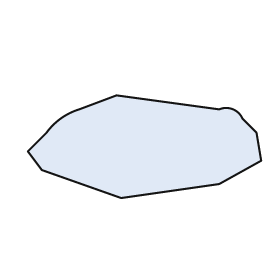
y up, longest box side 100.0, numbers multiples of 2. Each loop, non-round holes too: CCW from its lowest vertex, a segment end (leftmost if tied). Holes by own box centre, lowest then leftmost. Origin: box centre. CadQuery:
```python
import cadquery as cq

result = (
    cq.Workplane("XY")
    .moveTo(-10.0, -22.0)
    .lineTo(32.0, -16.0)
    .lineTo(50.0, -6.0)
    .lineTo(48.0, 6.0)
    .lineTo(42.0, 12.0)
    .threePointArc((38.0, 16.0), (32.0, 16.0))
    .lineTo(-12.0, 22.0)
    .lineTo(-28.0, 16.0)
    .threePointArc((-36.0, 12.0), (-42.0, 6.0))
    .lineTo(-50.0, -2.0)
    .lineTo(-44.0, -10.0)
    .close()
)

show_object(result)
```